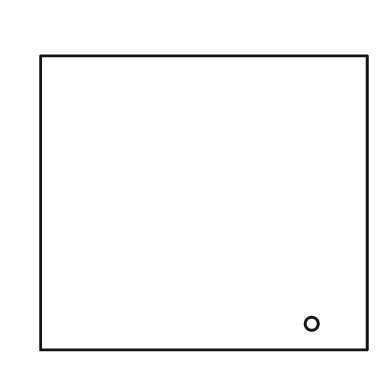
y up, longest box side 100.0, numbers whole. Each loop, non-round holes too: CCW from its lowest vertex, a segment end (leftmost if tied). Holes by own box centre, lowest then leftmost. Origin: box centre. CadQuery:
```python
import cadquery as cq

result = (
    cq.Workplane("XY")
    .moveTo(-50.0, -45.0)
    .lineTo(50.0, -45.0)
    .lineTo(50.0, 45.0)
    .lineTo(-50.0, 45.0)
    .close()
    .moveTo(33.0, -37.0)
    .circle(2.0)
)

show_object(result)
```